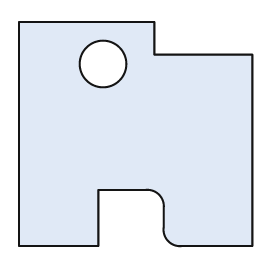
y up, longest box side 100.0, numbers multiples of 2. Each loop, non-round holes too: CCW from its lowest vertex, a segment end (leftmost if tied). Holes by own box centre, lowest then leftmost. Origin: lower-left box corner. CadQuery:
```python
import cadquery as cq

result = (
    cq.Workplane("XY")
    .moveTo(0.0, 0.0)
    .lineTo(34.0, 0.0)
    .lineTo(34.0, 24.0)
    .lineTo(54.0, 24.0)
    .threePointArc((60.0, 22.0), (62.0, 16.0))
    .lineTo(62.0, 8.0)
    .threePointArc((64.0, 2.0), (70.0, 0.0))
    .lineTo(100.0, 0.0)
    .lineTo(100.0, 82.0)
    .lineTo(58.0, 82.0)
    .lineTo(58.0, 96.0)
    .lineTo(0.0, 96.0)
    .close()
    .moveTo(36.0, 78.0)
    .circle(10.0)
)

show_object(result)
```